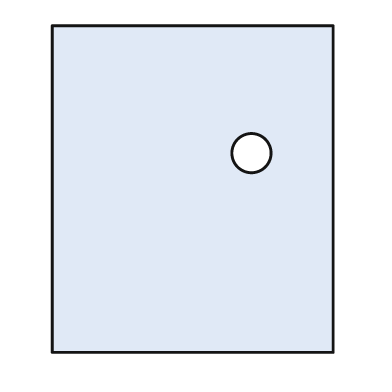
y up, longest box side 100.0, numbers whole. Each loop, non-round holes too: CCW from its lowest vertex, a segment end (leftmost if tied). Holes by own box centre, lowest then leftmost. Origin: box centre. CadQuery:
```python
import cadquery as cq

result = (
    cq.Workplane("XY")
    .moveTo(-43.0, -50.0)
    .lineTo(43.0, -50.0)
    .lineTo(43.0, 50.0)
    .lineTo(-43.0, 50.0)
    .close()
    .moveTo(18.0, 11.0)
    .circle(6.0)
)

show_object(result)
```